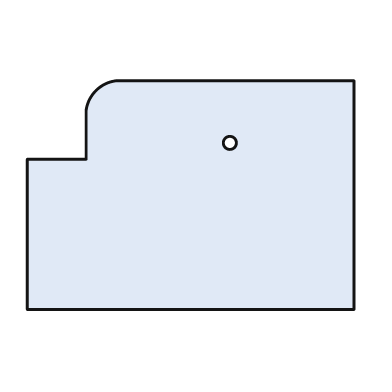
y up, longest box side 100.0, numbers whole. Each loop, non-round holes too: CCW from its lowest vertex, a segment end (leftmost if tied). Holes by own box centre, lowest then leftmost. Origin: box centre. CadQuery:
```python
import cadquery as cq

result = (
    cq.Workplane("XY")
    .moveTo(-50.0, -35.0)
    .lineTo(50.0, -35.0)
    .lineTo(50.0, 35.0)
    .lineTo(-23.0, 35.0)
    .threePointArc((-29.0, 32.0), (-32.0, 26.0))
    .lineTo(-32.0, 11.0)
    .lineTo(-50.0, 11.0)
    .close()
    .moveTo(12.0, 16.0)
    .circle(2.0)
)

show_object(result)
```